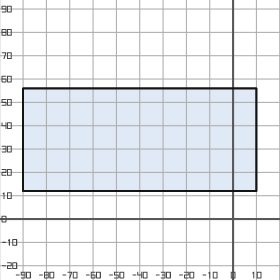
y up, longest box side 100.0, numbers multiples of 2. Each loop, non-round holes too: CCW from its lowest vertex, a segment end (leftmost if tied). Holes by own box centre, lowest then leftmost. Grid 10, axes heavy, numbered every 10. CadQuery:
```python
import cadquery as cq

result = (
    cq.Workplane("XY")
    .moveTo(-90.0, 12.0)
    .lineTo(10.0, 12.0)
    .lineTo(10.0, 56.0)
    .lineTo(-90.0, 56.0)
    .close()
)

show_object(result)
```